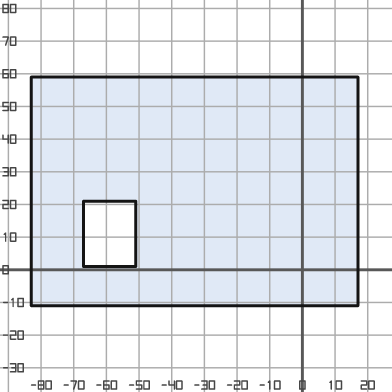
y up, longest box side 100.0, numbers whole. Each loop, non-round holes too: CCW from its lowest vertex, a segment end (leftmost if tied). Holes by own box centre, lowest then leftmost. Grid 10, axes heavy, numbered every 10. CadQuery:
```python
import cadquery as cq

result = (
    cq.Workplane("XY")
    .moveTo(-83.0, -11.0)
    .lineTo(17.0, -11.0)
    .lineTo(17.0, 59.0)
    .lineTo(-83.0, 59.0)
    .close()
    .moveTo(-67.0, 1.0)
    .lineTo(-51.0, 1.0)
    .lineTo(-51.0, 21.0)
    .lineTo(-67.0, 21.0)
    .close()
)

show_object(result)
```